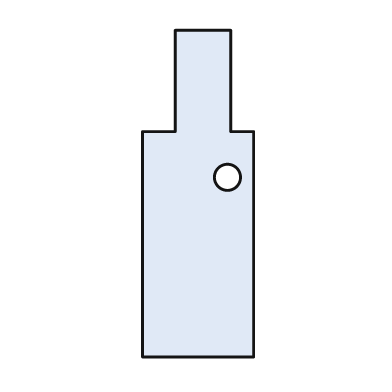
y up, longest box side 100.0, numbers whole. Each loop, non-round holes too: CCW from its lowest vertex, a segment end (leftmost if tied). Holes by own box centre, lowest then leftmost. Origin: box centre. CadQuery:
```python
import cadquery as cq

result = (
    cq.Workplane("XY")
    .moveTo(-17.0, -50.0)
    .lineTo(17.0, -50.0)
    .lineTo(17.0, 19.0)
    .lineTo(10.0, 19.0)
    .lineTo(10.0, 50.0)
    .lineTo(-7.0, 50.0)
    .lineTo(-7.0, 19.0)
    .lineTo(-17.0, 19.0)
    .close()
    .moveTo(9.0, 5.0)
    .circle(4.0)
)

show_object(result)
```